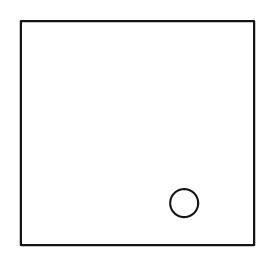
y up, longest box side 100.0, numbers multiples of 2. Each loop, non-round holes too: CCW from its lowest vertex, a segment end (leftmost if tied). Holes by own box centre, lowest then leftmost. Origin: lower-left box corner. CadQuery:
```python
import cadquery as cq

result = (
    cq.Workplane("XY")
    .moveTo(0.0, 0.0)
    .lineTo(100.0, 0.0)
    .lineTo(100.0, 96.0)
    .lineTo(0.0, 96.0)
    .close()
    .moveTo(70.0, 18.0)
    .circle(6.0)
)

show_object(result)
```